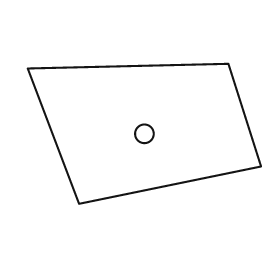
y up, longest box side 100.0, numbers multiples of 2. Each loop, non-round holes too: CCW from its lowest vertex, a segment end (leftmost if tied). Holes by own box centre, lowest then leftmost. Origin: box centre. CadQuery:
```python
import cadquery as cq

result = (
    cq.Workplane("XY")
    .moveTo(-28.0, -30.0)
    .lineTo(50.0, -14.0)
    .lineTo(36.0, 30.0)
    .lineTo(-50.0, 28.0)
    .close()
    .moveTo(0.0, 0.0)
    .circle(4.0)
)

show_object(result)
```